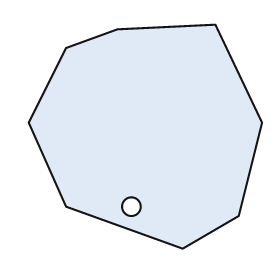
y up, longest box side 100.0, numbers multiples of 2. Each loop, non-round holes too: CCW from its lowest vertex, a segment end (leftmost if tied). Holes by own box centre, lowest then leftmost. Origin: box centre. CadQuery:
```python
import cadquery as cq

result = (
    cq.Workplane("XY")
    .moveTo(16.0, -48.0)
    .lineTo(40.0, -34.0)
    .lineTo(50.0, 6.0)
    .lineTo(30.0, 48.0)
    .lineTo(-12.0, 46.0)
    .lineTo(-34.0, 38.0)
    .lineTo(-50.0, 6.0)
    .lineTo(-34.0, -30.0)
    .close()
    .moveTo(-6.0, -30.0)
    .circle(4.0)
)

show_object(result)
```